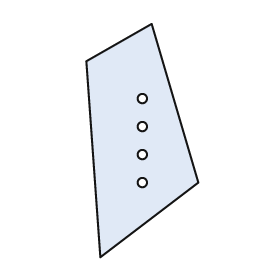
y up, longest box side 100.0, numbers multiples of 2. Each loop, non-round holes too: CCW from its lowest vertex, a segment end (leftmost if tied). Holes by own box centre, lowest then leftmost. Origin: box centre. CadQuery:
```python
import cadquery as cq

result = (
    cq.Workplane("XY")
    .moveTo(-18.0, -50.0)
    .lineTo(24.0, -18.0)
    .lineTo(4.0, 50.0)
    .lineTo(-24.0, 34.0)
    .close()
    .moveTo(0.0, -18.0)
    .circle(2.0)
    .moveTo(0.0, -6.0)
    .circle(2.0)
    .moveTo(0.0, 6.0)
    .circle(2.0)
    .moveTo(0.0, 18.0)
    .circle(2.0)
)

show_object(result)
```